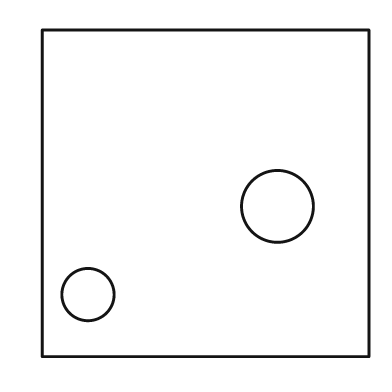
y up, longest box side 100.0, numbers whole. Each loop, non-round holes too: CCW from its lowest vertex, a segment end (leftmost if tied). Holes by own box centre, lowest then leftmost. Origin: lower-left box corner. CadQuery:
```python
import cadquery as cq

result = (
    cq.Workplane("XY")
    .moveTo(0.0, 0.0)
    .lineTo(100.0, 0.0)
    .lineTo(100.0, 100.0)
    .lineTo(0.0, 100.0)
    .close()
    .moveTo(14.0, 19.0)
    .circle(8.0)
    .moveTo(72.0, 46.0)
    .circle(11.0)
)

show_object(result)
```